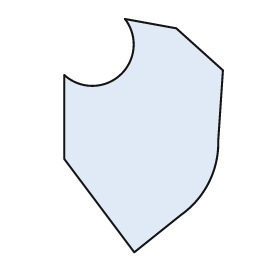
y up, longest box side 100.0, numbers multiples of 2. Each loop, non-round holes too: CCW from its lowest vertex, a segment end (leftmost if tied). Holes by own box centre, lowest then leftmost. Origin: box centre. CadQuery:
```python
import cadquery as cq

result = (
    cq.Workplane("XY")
    .moveTo(-4.0, -50.0)
    .lineTo(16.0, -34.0)
    .threePointArc((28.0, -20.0), (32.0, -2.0))
    .lineTo(34.0, 28.0)
    .lineTo(14.0, 46.0)
    .lineTo(-8.0, 50.0)
    .threePointArc((-10.0, 26.0), (-34.0, 26.0))
    .lineTo(-34.0, -10.0)
    .close()
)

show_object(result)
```